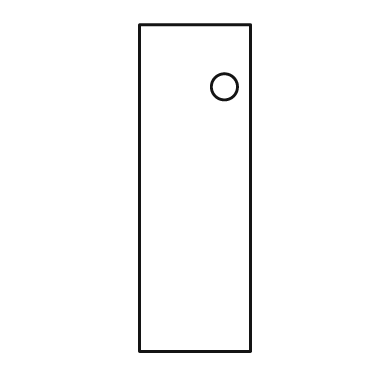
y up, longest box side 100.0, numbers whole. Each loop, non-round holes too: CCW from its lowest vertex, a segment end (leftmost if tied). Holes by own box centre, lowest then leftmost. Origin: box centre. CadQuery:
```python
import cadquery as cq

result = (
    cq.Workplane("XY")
    .moveTo(-17.0, -50.0)
    .lineTo(17.0, -50.0)
    .lineTo(17.0, 50.0)
    .lineTo(-17.0, 50.0)
    .close()
    .moveTo(9.0, 31.0)
    .circle(4.0)
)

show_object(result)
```